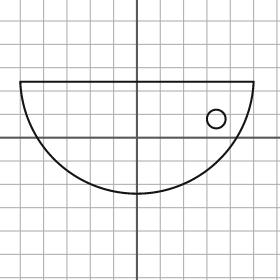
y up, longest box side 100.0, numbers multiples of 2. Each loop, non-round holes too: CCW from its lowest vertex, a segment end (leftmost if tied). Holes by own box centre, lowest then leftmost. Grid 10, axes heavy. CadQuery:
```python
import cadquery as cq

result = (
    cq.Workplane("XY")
    .moveTo(-50.0, 24.0)
    .threePointArc((0.0, -24.0), (50.0, 24.0))
    .close()
    .moveTo(34.0, 8.0)
    .circle(4.0)
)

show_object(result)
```